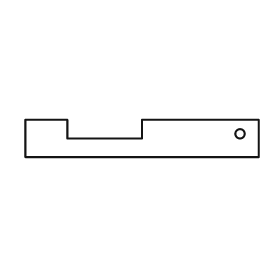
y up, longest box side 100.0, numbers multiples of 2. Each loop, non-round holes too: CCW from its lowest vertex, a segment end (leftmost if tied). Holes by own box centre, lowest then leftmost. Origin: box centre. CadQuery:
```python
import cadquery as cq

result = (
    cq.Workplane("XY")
    .moveTo(-50.0, -8.0)
    .lineTo(50.0, -8.0)
    .lineTo(50.0, 8.0)
    .lineTo(0.0, 8.0)
    .lineTo(0.0, 0.0)
    .lineTo(-32.0, 0.0)
    .lineTo(-32.0, 8.0)
    .lineTo(-50.0, 8.0)
    .close()
    .moveTo(42.0, 2.0)
    .circle(2.0)
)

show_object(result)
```